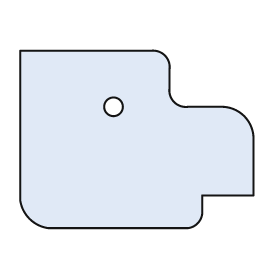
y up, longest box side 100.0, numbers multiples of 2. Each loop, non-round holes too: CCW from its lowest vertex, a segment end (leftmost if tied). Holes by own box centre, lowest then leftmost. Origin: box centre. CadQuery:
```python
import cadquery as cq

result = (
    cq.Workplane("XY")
    .moveTo(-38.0, -38.0)
    .lineTo(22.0, -38.0)
    .threePointArc((26.0, -36.0), (28.0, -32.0))
    .lineTo(28.0, -24.0)
    .lineTo(50.0, -24.0)
    .lineTo(50.0, 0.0)
    .threePointArc((46.0, 10.0), (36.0, 14.0))
    .lineTo(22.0, 14.0)
    .threePointArc((16.0, 16.0), (14.0, 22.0))
    .lineTo(14.0, 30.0)
    .threePointArc((12.0, 36.0), (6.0, 38.0))
    .lineTo(-50.0, 38.0)
    .lineTo(-50.0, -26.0)
    .threePointArc((-46.0, -34.0), (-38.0, -38.0))
    .close()
    .moveTo(-10.0, 14.0)
    .circle(4.0)
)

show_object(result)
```